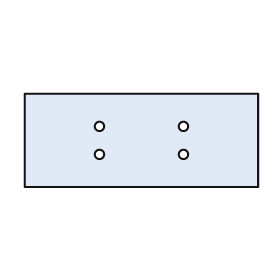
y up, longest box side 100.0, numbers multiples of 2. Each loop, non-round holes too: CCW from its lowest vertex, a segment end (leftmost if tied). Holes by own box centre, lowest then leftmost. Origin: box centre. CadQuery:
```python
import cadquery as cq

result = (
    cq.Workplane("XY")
    .moveTo(-50.0, -20.0)
    .lineTo(50.0, -20.0)
    .lineTo(50.0, 20.0)
    .lineTo(-50.0, 20.0)
    .close()
    .moveTo(-18.0, -6.0)
    .circle(2.0)
    .moveTo(18.0, -6.0)
    .circle(2.0)
    .moveTo(-18.0, 6.0)
    .circle(2.0)
    .moveTo(18.0, 6.0)
    .circle(2.0)
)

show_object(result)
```